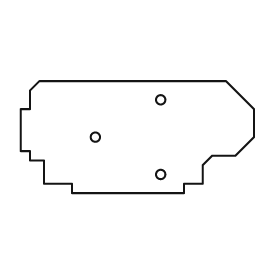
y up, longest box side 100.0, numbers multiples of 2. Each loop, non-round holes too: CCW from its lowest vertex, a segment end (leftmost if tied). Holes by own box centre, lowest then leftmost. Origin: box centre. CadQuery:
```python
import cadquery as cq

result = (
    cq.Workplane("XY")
    .moveTo(-28.0, -24.0)
    .lineTo(20.0, -24.0)
    .lineTo(20.0, -20.0)
    .lineTo(28.0, -20.0)
    .lineTo(28.0, -12.0)
    .lineTo(32.0, -8.0)
    .lineTo(42.0, -8.0)
    .lineTo(50.0, 0.0)
    .lineTo(50.0, 12.0)
    .lineTo(38.0, 24.0)
    .lineTo(-42.0, 24.0)
    .lineTo(-46.0, 20.0)
    .lineTo(-46.0, 12.0)
    .lineTo(-50.0, 12.0)
    .lineTo(-50.0, -6.0)
    .lineTo(-46.0, -6.0)
    .lineTo(-46.0, -10.0)
    .lineTo(-40.0, -10.0)
    .lineTo(-40.0, -20.0)
    .lineTo(-28.0, -20.0)
    .close()
    .moveTo(10.0, -16.0)
    .circle(2.0)
    .moveTo(-18.0, 0.0)
    .circle(2.0)
    .moveTo(10.0, 16.0)
    .circle(2.0)
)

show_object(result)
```